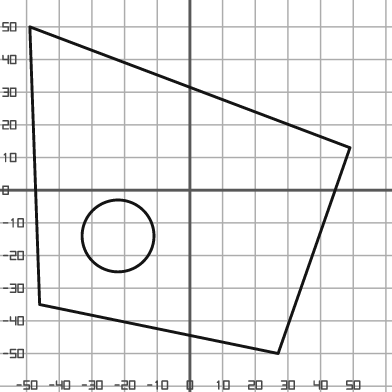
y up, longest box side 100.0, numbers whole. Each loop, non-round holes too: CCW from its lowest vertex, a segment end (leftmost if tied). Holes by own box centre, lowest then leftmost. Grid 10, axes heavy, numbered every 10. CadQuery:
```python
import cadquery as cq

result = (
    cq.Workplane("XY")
    .moveTo(27.0, -50.0)
    .lineTo(49.0, 13.0)
    .lineTo(-49.0, 50.0)
    .lineTo(-46.0, -35.0)
    .close()
    .moveTo(-22.0, -14.0)
    .circle(11.0)
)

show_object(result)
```